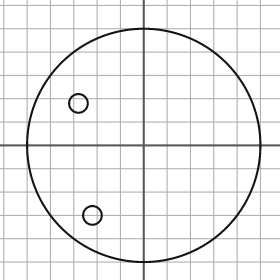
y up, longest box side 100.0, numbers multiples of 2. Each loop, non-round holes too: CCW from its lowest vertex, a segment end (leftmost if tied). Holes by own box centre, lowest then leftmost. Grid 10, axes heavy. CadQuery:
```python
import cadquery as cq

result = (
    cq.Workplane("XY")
    .moveTo(0.0, 0.0)
    .circle(50.0)
    .moveTo(-22.0, -30.0)
    .circle(4.0)
    .moveTo(-28.0, 18.0)
    .circle(4.0)
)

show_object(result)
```